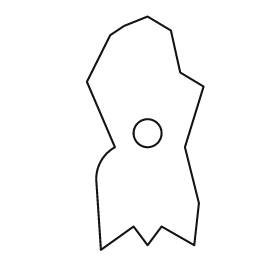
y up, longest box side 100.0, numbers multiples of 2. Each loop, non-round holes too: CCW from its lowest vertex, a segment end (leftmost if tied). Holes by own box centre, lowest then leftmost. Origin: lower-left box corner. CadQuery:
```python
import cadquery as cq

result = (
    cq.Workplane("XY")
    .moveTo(6.0, 0.0)
    .lineTo(20.0, 10.0)
    .lineTo(26.0, 2.0)
    .lineTo(32.0, 10.0)
    .lineTo(46.0, 2.0)
    .lineTo(48.0, 20.0)
    .lineTo(42.0, 44.0)
    .lineTo(50.0, 70.0)
    .lineTo(40.0, 76.0)
    .lineTo(36.0, 94.0)
    .lineTo(26.0, 100.0)
    .lineTo(16.0, 96.0)
    .lineTo(10.0, 92.0)
    .lineTo(0.0, 72.0)
    .lineTo(12.0, 44.0)
    .threePointArc((6.0, 38.0), (4.0, 30.0))
    .close()
    .moveTo(26.0, 50.0)
    .circle(6.0)
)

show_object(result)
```